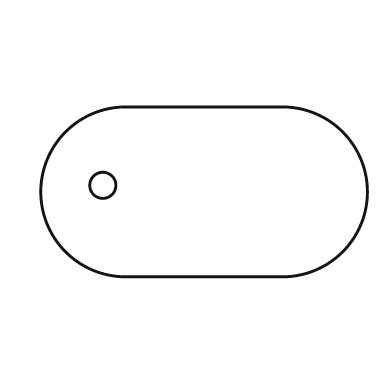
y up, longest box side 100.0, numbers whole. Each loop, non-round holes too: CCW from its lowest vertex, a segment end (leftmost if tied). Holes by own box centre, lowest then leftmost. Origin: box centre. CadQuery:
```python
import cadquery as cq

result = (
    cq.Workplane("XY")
    .moveTo(-24.0, -26.0)
    .lineTo(24.0, -26.0)
    .threePointArc((50.0, 0.0), (24.0, 26.0))
    .lineTo(-24.0, 26.0)
    .threePointArc((-50.0, 0.0), (-24.0, -26.0))
    .close()
    .moveTo(-31.0, 2.0)
    .circle(4.0)
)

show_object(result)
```